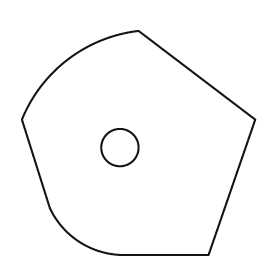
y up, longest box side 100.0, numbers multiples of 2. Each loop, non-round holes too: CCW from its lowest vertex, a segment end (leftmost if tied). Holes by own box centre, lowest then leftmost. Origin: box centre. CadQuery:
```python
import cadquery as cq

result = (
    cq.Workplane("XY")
    .moveTo(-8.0, -48.0)
    .lineTo(30.0, -48.0)
    .lineTo(50.0, 10.0)
    .lineTo(0.0, 48.0)
    .threePointArc((-30.0, 36.0), (-50.0, 10.0))
    .lineTo(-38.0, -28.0)
    .threePointArc((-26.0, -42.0), (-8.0, -48.0))
    .close()
    .moveTo(-8.0, -2.0)
    .circle(8.0)
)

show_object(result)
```